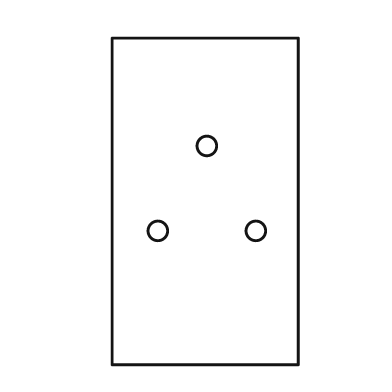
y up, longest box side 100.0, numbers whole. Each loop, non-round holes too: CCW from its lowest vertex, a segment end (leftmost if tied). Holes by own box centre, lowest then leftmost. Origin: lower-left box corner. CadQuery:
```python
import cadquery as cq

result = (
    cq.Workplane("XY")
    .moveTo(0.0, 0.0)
    .lineTo(57.0, 0.0)
    .lineTo(57.0, 100.0)
    .lineTo(0.0, 100.0)
    .close()
    .moveTo(14.0, 41.0)
    .circle(3.0)
    .moveTo(44.0, 41.0)
    .circle(3.0)
    .moveTo(29.0, 67.0)
    .circle(3.0)
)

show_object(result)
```